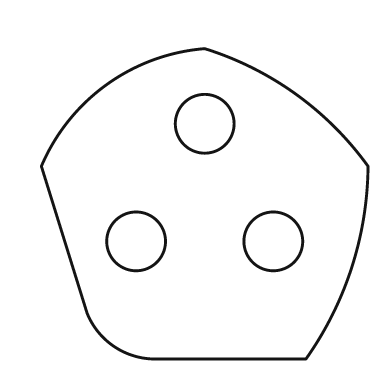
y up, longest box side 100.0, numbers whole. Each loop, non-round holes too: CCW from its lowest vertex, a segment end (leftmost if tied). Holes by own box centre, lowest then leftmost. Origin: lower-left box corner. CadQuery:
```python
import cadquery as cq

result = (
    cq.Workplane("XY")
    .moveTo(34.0, 0.0)
    .lineTo(81.0, 0.0)
    .threePointArc((95.0, 28.0), (100.0, 59.0))
    .threePointArc((78.0, 81.0), (50.0, 95.0))
    .threePointArc((20.0, 84.0), (0.0, 59.0))
    .lineTo(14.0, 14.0)
    .threePointArc((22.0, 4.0), (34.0, 0.0))
    .close()
    .moveTo(29.0, 36.0)
    .circle(9.0)
    .moveTo(71.0, 36.0)
    .circle(9.0)
    .moveTo(50.0, 72.0)
    .circle(9.0)
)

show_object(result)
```